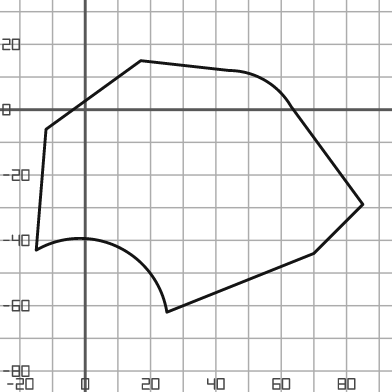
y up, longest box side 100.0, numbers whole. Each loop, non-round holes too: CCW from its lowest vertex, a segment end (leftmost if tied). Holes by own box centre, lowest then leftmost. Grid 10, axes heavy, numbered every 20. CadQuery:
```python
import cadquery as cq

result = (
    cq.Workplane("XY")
    .moveTo(25.0, -62.0)
    .lineTo(70.0, -44.0)
    .lineTo(85.0, -29.0)
    .lineTo(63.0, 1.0)
    .threePointArc((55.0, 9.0), (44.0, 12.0))
    .lineTo(17.0, 15.0)
    .lineTo(-12.0, -6.0)
    .lineTo(-15.0, -43.0)
    .threePointArc((10.0, -42.0), (25.0, -62.0))
    .close()
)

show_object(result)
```